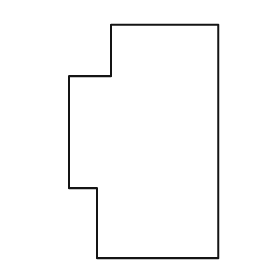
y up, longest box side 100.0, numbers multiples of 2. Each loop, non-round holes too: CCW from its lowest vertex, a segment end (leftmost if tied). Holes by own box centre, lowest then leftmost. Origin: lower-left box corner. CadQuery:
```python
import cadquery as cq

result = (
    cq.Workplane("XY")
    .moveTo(12.0, 0.0)
    .lineTo(64.0, 0.0)
    .lineTo(64.0, 100.0)
    .lineTo(18.0, 100.0)
    .lineTo(18.0, 78.0)
    .lineTo(0.0, 78.0)
    .lineTo(0.0, 30.0)
    .lineTo(12.0, 30.0)
    .close()
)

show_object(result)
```